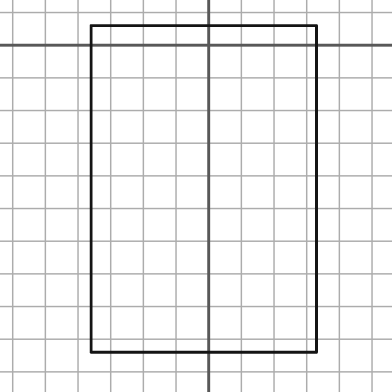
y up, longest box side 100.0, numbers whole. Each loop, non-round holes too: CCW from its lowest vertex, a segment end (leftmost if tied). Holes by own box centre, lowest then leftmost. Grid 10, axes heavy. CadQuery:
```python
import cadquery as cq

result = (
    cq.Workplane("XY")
    .moveTo(-36.0, -94.0)
    .lineTo(33.0, -94.0)
    .lineTo(33.0, 6.0)
    .lineTo(-36.0, 6.0)
    .close()
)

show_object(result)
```